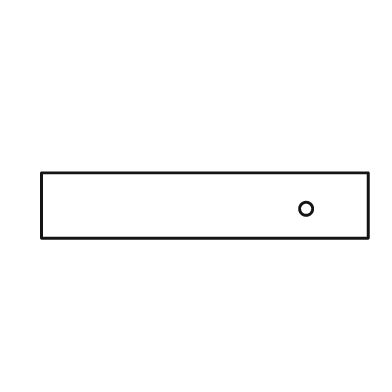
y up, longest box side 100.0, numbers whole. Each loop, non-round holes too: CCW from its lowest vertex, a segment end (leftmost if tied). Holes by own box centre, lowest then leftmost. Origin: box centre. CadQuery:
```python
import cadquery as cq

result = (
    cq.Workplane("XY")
    .moveTo(-50.0, -10.0)
    .lineTo(50.0, -10.0)
    .lineTo(50.0, 10.0)
    .lineTo(-50.0, 10.0)
    .close()
    .moveTo(31.0, -1.0)
    .circle(2.0)
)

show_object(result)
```